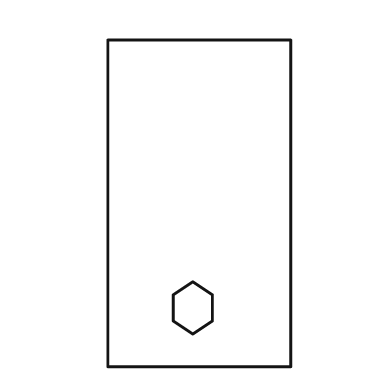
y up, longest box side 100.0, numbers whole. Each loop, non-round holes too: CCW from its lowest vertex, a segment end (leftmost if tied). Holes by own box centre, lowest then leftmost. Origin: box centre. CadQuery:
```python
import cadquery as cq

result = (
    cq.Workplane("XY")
    .moveTo(-28.0, -50.0)
    .lineTo(28.0, -50.0)
    .lineTo(28.0, 50.0)
    .lineTo(-28.0, 50.0)
    .close()
    .moveTo(-2.0, -40.0)
    .lineTo(4.0, -36.0)
    .lineTo(4.0, -28.0)
    .lineTo(-2.0, -24.0)
    .lineTo(-8.0, -28.0)
    .lineTo(-8.0, -36.0)
    .close()
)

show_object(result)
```